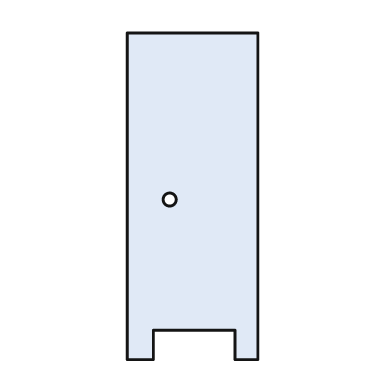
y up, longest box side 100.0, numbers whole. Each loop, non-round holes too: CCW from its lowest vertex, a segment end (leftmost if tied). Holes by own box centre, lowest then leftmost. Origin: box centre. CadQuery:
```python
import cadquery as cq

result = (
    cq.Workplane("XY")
    .moveTo(-20.0, -50.0)
    .lineTo(-12.0, -50.0)
    .lineTo(-12.0, -41.0)
    .lineTo(13.0, -41.0)
    .lineTo(13.0, -50.0)
    .lineTo(20.0, -50.0)
    .lineTo(20.0, 50.0)
    .lineTo(-20.0, 50.0)
    .close()
    .moveTo(-7.0, -1.0)
    .circle(2.0)
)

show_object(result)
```